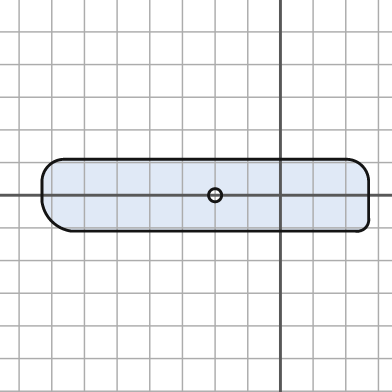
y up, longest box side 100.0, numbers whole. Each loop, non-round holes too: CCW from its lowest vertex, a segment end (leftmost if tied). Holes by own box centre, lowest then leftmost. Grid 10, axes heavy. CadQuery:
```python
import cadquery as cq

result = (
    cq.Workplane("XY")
    .moveTo(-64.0, -11.0)
    .lineTo(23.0, -11.0)
    .threePointArc((26.0, -10.0), (27.0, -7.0))
    .lineTo(27.0, 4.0)
    .threePointArc((25.0, 9.0), (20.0, 11.0))
    .lineTo(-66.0, 11.0)
    .threePointArc((-71.0, 9.0), (-73.0, 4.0))
    .lineTo(-73.0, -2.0)
    .threePointArc((-70.0, -8.0), (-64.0, -11.0))
    .close()
    .moveTo(-20.0, 0.0)
    .circle(2.0)
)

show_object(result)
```